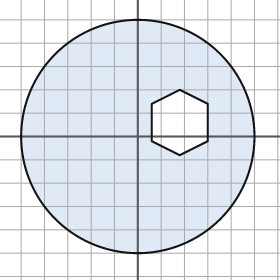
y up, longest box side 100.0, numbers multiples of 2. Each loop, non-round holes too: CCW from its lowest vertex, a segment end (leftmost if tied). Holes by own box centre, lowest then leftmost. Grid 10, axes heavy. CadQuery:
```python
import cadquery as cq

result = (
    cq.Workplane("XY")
    .moveTo(0.0, 0.0)
    .circle(50.0)
    .moveTo(18.0, -8.0)
    .lineTo(30.0, -2.0)
    .lineTo(30.0, 14.0)
    .lineTo(18.0, 20.0)
    .lineTo(6.0, 14.0)
    .lineTo(6.0, -2.0)
    .close()
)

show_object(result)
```